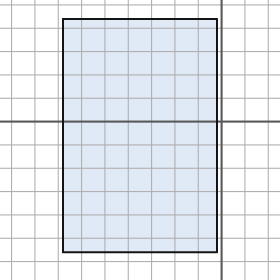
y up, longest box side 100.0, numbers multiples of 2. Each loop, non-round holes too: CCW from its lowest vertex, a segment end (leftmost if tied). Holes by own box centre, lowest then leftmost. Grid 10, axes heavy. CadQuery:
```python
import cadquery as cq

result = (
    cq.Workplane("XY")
    .moveTo(-68.0, -56.0)
    .lineTo(-2.0, -56.0)
    .lineTo(-2.0, 44.0)
    .lineTo(-68.0, 44.0)
    .close()
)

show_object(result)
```